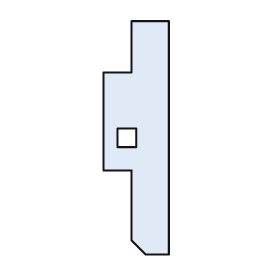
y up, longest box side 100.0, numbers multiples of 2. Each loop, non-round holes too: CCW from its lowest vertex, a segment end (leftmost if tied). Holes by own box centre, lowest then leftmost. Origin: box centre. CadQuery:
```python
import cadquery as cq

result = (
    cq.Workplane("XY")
    .moveTo(4.0, -50.0)
    .lineTo(14.0, -50.0)
    .lineTo(14.0, 50.0)
    .lineTo(-2.0, 50.0)
    .lineTo(-2.0, 28.0)
    .lineTo(-14.0, 28.0)
    .lineTo(-14.0, -14.0)
    .lineTo(-2.0, -14.0)
    .lineTo(-2.0, -44.0)
    .close()
    .moveTo(-8.0, -4.0)
    .lineTo(0.0, -4.0)
    .lineTo(0.0, 4.0)
    .lineTo(-8.0, 4.0)
    .close()
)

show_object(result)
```